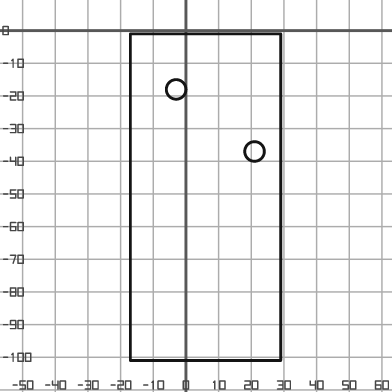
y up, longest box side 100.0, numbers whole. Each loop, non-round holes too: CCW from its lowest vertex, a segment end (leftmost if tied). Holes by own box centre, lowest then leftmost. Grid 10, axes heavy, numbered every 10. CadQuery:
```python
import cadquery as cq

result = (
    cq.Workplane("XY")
    .moveTo(-17.0, -101.0)
    .lineTo(29.0, -101.0)
    .lineTo(29.0, -1.0)
    .lineTo(-17.0, -1.0)
    .close()
    .moveTo(21.0, -37.0)
    .circle(3.0)
    .moveTo(-3.0, -18.0)
    .circle(3.0)
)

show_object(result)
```